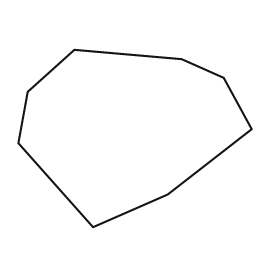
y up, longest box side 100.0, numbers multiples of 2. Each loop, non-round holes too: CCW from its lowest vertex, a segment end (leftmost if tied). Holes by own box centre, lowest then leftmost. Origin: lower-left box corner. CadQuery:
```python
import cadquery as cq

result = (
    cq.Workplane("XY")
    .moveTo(32.0, 0.0)
    .lineTo(64.0, 14.0)
    .lineTo(100.0, 42.0)
    .lineTo(88.0, 64.0)
    .lineTo(70.0, 72.0)
    .lineTo(24.0, 76.0)
    .lineTo(4.0, 58.0)
    .lineTo(0.0, 36.0)
    .close()
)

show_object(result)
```